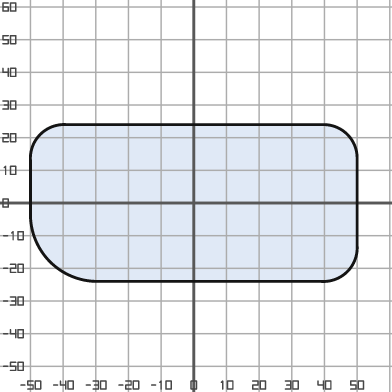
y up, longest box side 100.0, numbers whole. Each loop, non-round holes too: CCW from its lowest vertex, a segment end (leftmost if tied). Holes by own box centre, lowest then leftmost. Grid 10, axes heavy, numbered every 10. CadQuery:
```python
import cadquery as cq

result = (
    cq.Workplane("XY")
    .moveTo(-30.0, -24.0)
    .lineTo(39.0, -24.0)
    .threePointArc((47.0, -21.0), (50.0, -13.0))
    .lineTo(50.0, 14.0)
    .threePointArc((47.0, 21.0), (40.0, 24.0))
    .lineTo(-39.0, 24.0)
    .threePointArc((-47.0, 21.0), (-50.0, 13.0))
    .lineTo(-50.0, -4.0)
    .threePointArc((-44.0, -18.0), (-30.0, -24.0))
    .close()
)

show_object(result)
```